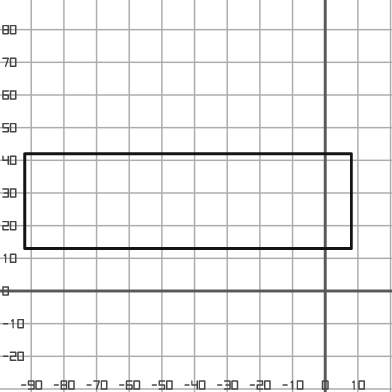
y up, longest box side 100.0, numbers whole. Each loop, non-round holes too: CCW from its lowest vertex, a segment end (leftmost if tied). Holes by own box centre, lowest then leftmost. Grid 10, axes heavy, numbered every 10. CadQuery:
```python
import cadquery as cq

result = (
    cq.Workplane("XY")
    .moveTo(-92.0, 13.0)
    .lineTo(8.0, 13.0)
    .lineTo(8.0, 42.0)
    .lineTo(-92.0, 42.0)
    .close()
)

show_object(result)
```